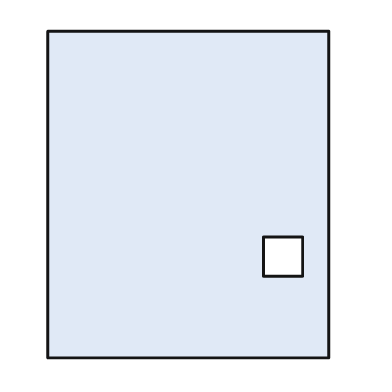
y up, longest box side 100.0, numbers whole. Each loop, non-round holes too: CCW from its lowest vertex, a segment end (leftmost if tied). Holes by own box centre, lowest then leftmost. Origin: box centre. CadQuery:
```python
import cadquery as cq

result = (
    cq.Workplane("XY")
    .moveTo(-43.0, -50.0)
    .lineTo(43.0, -50.0)
    .lineTo(43.0, 50.0)
    .lineTo(-43.0, 50.0)
    .close()
    .moveTo(23.0, -25.0)
    .lineTo(35.0, -25.0)
    .lineTo(35.0, -13.0)
    .lineTo(23.0, -13.0)
    .close()
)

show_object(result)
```